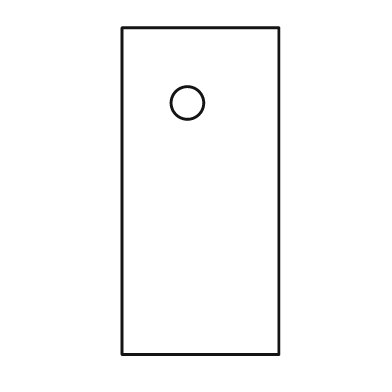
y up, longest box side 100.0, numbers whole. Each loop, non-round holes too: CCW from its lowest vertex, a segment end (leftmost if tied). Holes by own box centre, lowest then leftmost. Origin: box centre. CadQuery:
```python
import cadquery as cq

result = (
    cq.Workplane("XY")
    .moveTo(-24.0, -50.0)
    .lineTo(24.0, -50.0)
    .lineTo(24.0, 50.0)
    .lineTo(-24.0, 50.0)
    .close()
    .moveTo(-4.0, 27.0)
    .circle(5.0)
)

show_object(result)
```